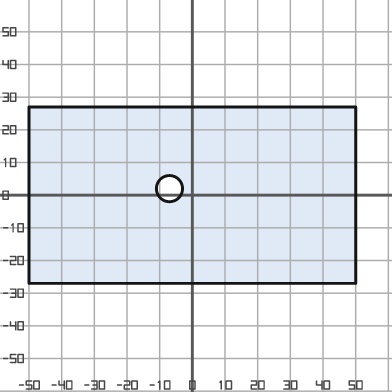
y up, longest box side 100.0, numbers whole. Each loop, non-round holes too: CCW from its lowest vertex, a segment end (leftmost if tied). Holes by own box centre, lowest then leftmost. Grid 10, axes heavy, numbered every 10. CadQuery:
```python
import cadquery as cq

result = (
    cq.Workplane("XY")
    .moveTo(-50.0, -27.0)
    .lineTo(50.0, -27.0)
    .lineTo(50.0, 27.0)
    .lineTo(-50.0, 27.0)
    .close()
    .moveTo(-7.0, 2.0)
    .circle(4.0)
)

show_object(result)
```